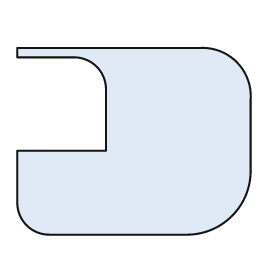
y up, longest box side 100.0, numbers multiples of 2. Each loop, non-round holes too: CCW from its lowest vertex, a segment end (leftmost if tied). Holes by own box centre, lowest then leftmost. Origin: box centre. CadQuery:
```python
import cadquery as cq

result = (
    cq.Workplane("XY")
    .moveTo(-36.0, -40.0)
    .lineTo(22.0, -40.0)
    .threePointArc((42.0, -32.0), (50.0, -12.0))
    .lineTo(50.0, 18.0)
    .threePointArc((44.0, 34.0), (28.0, 40.0))
    .lineTo(-50.0, 40.0)
    .lineTo(-50.0, 36.0)
    .lineTo(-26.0, 36.0)
    .threePointArc((-16.0, 32.0), (-12.0, 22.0))
    .lineTo(-12.0, -4.0)
    .lineTo(-50.0, -4.0)
    .lineTo(-50.0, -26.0)
    .threePointArc((-46.0, -36.0), (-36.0, -40.0))
    .close()
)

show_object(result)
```